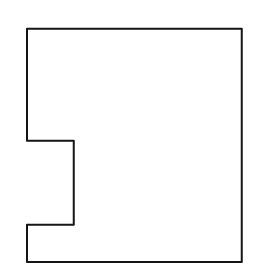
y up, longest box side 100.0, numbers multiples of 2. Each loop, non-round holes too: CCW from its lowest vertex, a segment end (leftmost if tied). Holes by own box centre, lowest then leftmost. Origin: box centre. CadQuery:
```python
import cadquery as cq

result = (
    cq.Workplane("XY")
    .moveTo(-46.0, -50.0)
    .lineTo(46.0, -50.0)
    .lineTo(46.0, 50.0)
    .lineTo(-46.0, 50.0)
    .lineTo(-46.0, 2.0)
    .lineTo(-26.0, 2.0)
    .lineTo(-26.0, -34.0)
    .lineTo(-46.0, -34.0)
    .close()
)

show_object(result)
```